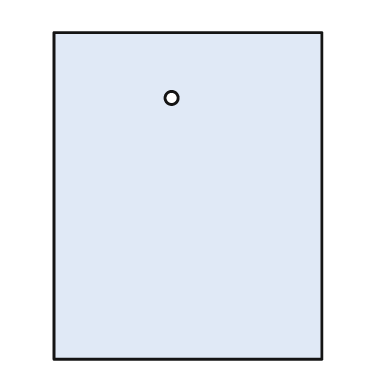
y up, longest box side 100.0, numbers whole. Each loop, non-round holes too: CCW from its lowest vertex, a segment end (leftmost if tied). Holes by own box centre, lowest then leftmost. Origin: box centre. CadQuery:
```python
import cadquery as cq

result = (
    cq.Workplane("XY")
    .moveTo(-41.0, -50.0)
    .lineTo(41.0, -50.0)
    .lineTo(41.0, 50.0)
    .lineTo(-41.0, 50.0)
    .close()
    .moveTo(-5.0, 30.0)
    .circle(2.0)
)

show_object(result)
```